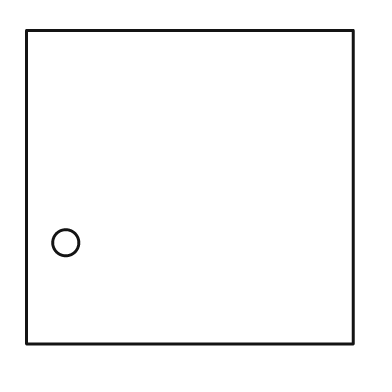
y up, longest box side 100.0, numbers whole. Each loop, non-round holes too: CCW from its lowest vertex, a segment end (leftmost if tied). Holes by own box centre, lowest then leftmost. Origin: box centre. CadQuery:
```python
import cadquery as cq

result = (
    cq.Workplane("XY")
    .moveTo(-50.0, -48.0)
    .lineTo(50.0, -48.0)
    .lineTo(50.0, 48.0)
    .lineTo(-50.0, 48.0)
    .close()
    .moveTo(-38.0, -17.0)
    .circle(4.0)
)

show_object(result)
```